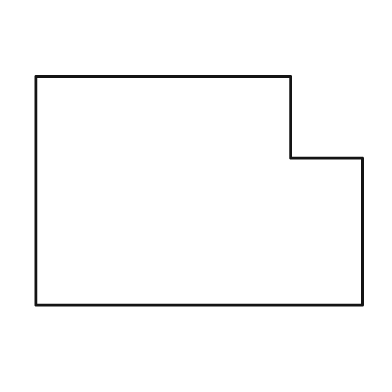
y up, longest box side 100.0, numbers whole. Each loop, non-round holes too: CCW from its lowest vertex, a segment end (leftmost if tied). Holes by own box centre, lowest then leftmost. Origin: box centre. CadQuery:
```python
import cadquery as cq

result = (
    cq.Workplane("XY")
    .moveTo(-50.0, -35.0)
    .lineTo(50.0, -35.0)
    .lineTo(50.0, 10.0)
    .lineTo(28.0, 10.0)
    .lineTo(28.0, 35.0)
    .lineTo(-50.0, 35.0)
    .close()
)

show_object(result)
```